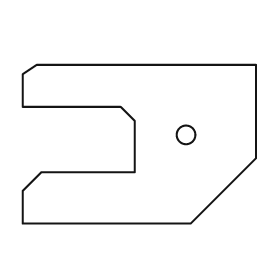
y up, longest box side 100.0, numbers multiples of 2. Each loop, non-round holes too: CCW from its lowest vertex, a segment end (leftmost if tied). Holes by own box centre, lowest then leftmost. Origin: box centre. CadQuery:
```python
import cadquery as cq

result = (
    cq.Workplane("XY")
    .moveTo(-50.0, -34.0)
    .lineTo(22.0, -34.0)
    .lineTo(50.0, -6.0)
    .lineTo(50.0, 34.0)
    .lineTo(-44.0, 34.0)
    .lineTo(-50.0, 30.0)
    .lineTo(-50.0, 16.0)
    .lineTo(-8.0, 16.0)
    .lineTo(-2.0, 10.0)
    .lineTo(-2.0, -12.0)
    .lineTo(-42.0, -12.0)
    .lineTo(-50.0, -20.0)
    .close()
    .moveTo(20.0, 4.0)
    .circle(4.0)
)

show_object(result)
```